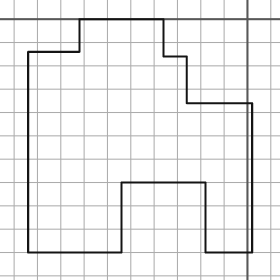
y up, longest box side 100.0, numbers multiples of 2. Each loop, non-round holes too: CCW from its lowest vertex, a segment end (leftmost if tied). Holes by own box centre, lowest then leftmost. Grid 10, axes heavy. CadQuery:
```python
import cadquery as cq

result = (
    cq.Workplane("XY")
    .moveTo(-94.0, -100.0)
    .lineTo(-54.0, -100.0)
    .lineTo(-54.0, -70.0)
    .lineTo(-18.0, -70.0)
    .lineTo(-18.0, -100.0)
    .lineTo(2.0, -100.0)
    .lineTo(2.0, -36.0)
    .lineTo(-26.0, -36.0)
    .lineTo(-26.0, -16.0)
    .lineTo(-36.0, -16.0)
    .lineTo(-36.0, 0.0)
    .lineTo(-72.0, 0.0)
    .lineTo(-72.0, -14.0)
    .lineTo(-94.0, -14.0)
    .close()
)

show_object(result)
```